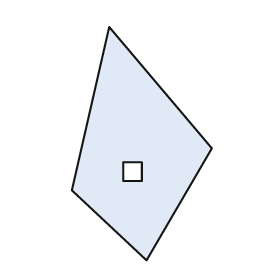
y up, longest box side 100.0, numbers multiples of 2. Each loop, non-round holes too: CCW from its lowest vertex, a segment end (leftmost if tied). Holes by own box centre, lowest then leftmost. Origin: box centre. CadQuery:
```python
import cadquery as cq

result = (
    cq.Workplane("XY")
    .moveTo(2.0, -50.0)
    .lineTo(30.0, -2.0)
    .lineTo(-14.0, 50.0)
    .lineTo(-30.0, -20.0)
    .close()
    .moveTo(-8.0, -16.0)
    .lineTo(0.0, -16.0)
    .lineTo(0.0, -8.0)
    .lineTo(-8.0, -8.0)
    .close()
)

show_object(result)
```